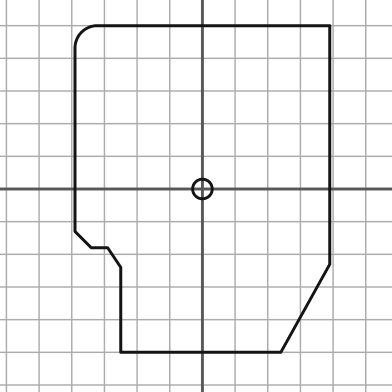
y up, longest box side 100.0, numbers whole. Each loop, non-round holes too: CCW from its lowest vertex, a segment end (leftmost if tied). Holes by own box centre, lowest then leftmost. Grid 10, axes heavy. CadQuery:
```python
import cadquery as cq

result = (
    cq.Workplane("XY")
    .moveTo(-25.0, -50.0)
    .lineTo(24.0, -50.0)
    .lineTo(39.0, -23.0)
    .lineTo(39.0, 50.0)
    .lineTo(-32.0, 50.0)
    .threePointArc((-37.0, 48.0), (-39.0, 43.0))
    .lineTo(-39.0, -13.0)
    .lineTo(-34.0, -18.0)
    .lineTo(-29.0, -18.0)
    .lineTo(-25.0, -24.0)
    .close()
    .moveTo(0.0, 0.0)
    .circle(3.0)
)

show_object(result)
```